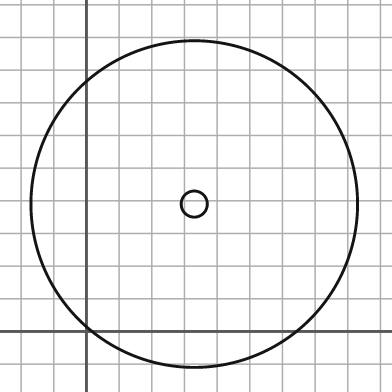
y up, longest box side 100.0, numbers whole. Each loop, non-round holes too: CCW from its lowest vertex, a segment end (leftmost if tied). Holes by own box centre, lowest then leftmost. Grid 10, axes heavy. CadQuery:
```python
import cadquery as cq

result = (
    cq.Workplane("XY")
    .moveTo(33.0, 39.0)
    .circle(50.0)
    .moveTo(33.0, 39.0)
    .circle(4.0)
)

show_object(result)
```